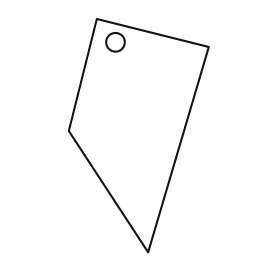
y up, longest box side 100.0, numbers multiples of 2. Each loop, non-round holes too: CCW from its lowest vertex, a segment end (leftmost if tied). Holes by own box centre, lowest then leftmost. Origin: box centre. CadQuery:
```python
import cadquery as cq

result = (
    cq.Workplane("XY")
    .moveTo(4.0, -50.0)
    .lineTo(30.0, 38.0)
    .lineTo(-18.0, 50.0)
    .lineTo(-30.0, 2.0)
    .close()
    .moveTo(-10.0, 40.0)
    .circle(4.0)
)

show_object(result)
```